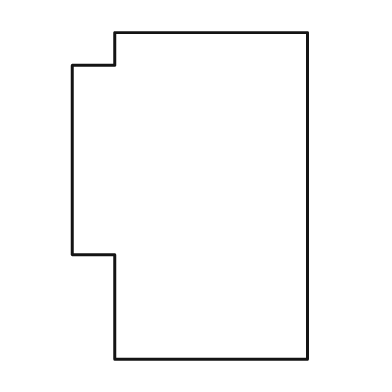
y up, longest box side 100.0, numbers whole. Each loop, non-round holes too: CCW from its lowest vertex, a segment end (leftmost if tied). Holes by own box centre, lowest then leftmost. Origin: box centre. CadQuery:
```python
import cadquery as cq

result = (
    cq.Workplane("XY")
    .moveTo(-23.0, -50.0)
    .lineTo(36.0, -50.0)
    .lineTo(36.0, 50.0)
    .lineTo(-23.0, 50.0)
    .lineTo(-23.0, 40.0)
    .lineTo(-36.0, 40.0)
    .lineTo(-36.0, -18.0)
    .lineTo(-23.0, -18.0)
    .close()
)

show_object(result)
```